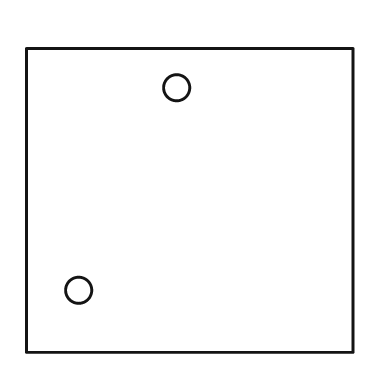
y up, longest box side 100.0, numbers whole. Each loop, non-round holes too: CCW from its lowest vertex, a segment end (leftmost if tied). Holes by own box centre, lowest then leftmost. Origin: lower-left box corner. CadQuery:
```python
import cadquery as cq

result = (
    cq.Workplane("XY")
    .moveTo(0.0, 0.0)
    .lineTo(100.0, 0.0)
    .lineTo(100.0, 93.0)
    .lineTo(0.0, 93.0)
    .close()
    .moveTo(16.0, 19.0)
    .circle(4.0)
    .moveTo(46.0, 81.0)
    .circle(4.0)
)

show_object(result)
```